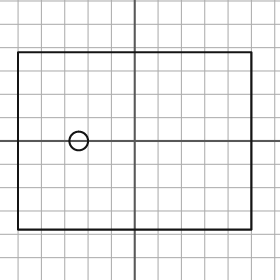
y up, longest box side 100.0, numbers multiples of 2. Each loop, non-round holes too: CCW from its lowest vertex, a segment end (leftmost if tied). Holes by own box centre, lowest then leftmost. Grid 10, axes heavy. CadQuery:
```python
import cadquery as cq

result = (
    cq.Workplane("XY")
    .moveTo(-50.0, -38.0)
    .lineTo(50.0, -38.0)
    .lineTo(50.0, 38.0)
    .lineTo(-50.0, 38.0)
    .close()
    .moveTo(-24.0, 0.0)
    .circle(4.0)
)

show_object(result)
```